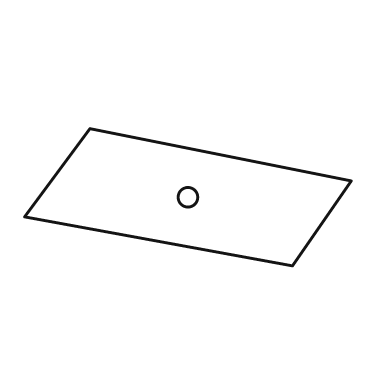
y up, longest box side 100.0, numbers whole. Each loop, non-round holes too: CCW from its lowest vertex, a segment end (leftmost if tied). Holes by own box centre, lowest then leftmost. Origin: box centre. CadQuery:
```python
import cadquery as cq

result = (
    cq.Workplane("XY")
    .moveTo(32.0, -21.0)
    .lineTo(50.0, 5.0)
    .lineTo(-30.0, 21.0)
    .lineTo(-50.0, -6.0)
    .close()
    .moveTo(0.0, 0.0)
    .circle(3.0)
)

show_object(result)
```